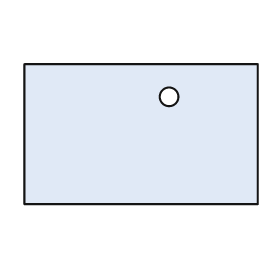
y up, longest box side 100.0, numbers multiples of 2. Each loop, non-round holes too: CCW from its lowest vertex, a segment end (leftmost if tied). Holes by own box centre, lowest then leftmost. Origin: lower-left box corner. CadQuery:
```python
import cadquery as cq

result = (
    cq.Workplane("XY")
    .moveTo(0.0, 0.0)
    .lineTo(100.0, 0.0)
    .lineTo(100.0, 60.0)
    .lineTo(0.0, 60.0)
    .close()
    .moveTo(62.0, 46.0)
    .circle(4.0)
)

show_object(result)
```